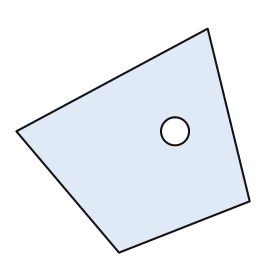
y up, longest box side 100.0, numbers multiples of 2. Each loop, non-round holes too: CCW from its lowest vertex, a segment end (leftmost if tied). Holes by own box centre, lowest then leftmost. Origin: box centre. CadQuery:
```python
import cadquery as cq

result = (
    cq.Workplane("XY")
    .moveTo(-6.0, -48.0)
    .lineTo(50.0, -26.0)
    .lineTo(32.0, 48.0)
    .lineTo(-50.0, 4.0)
    .close()
    .moveTo(18.0, 4.0)
    .circle(6.0)
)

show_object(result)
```